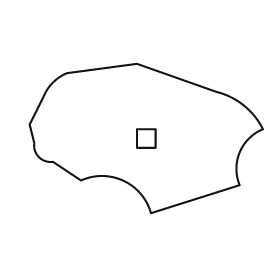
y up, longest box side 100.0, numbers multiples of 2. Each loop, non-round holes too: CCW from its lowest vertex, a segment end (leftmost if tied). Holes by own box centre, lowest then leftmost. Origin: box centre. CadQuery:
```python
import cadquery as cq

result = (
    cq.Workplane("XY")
    .moveTo(2.0, -32.0)
    .lineTo(40.0, -20.0)
    .threePointArc((40.0, -6.0), (50.0, 4.0))
    .threePointArc((42.0, 14.0), (30.0, 20.0))
    .lineTo(-4.0, 32.0)
    .lineTo(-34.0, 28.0)
    .threePointArc((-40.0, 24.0), (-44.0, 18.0))
    .lineTo(-50.0, 6.0)
    .lineTo(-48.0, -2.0)
    .threePointArc((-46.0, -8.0), (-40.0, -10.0))
    .lineTo(-28.0, -18.0)
    .threePointArc((-10.0, -18.0), (2.0, -32.0))
    .close()
    .moveTo(-4.0, -4.0)
    .lineTo(4.0, -4.0)
    .lineTo(4.0, 4.0)
    .lineTo(-4.0, 4.0)
    .close()
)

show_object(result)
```